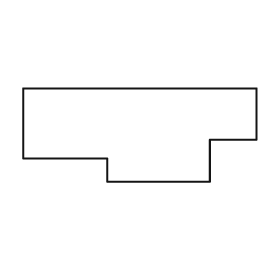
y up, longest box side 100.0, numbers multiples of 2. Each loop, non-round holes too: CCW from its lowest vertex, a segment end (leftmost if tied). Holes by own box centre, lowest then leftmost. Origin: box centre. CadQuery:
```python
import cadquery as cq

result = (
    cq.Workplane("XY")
    .moveTo(-14.0, -20.0)
    .lineTo(30.0, -20.0)
    .lineTo(30.0, -2.0)
    .lineTo(50.0, -2.0)
    .lineTo(50.0, 20.0)
    .lineTo(-50.0, 20.0)
    .lineTo(-50.0, -10.0)
    .lineTo(-14.0, -10.0)
    .close()
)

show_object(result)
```